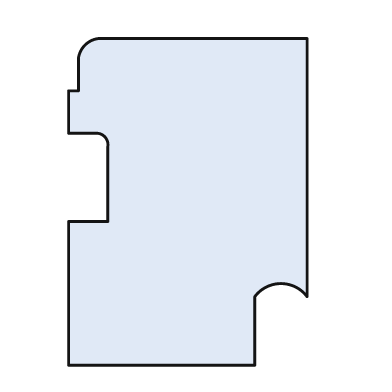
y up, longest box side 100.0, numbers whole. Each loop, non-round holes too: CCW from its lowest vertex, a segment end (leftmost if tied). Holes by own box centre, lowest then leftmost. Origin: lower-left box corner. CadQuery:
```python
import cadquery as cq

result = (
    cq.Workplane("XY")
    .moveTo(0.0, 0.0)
    .lineTo(57.0, 0.0)
    .lineTo(57.0, 21.0)
    .threePointArc((65.0, 25.0), (73.0, 21.0))
    .lineTo(73.0, 100.0)
    .lineTo(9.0, 100.0)
    .threePointArc((5.0, 98.0), (3.0, 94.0))
    .lineTo(3.0, 84.0)
    .lineTo(0.0, 84.0)
    .lineTo(0.0, 71.0)
    .lineTo(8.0, 71.0)
    .threePointArc((11.0, 70.0), (12.0, 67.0))
    .lineTo(12.0, 44.0)
    .lineTo(0.0, 44.0)
    .close()
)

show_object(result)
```